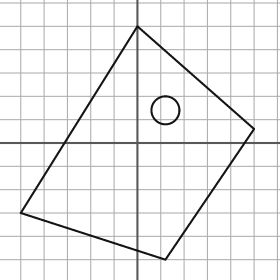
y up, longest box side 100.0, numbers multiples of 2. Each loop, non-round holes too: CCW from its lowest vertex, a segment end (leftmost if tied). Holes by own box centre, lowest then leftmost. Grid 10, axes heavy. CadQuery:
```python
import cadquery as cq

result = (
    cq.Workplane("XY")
    .moveTo(12.0, -50.0)
    .lineTo(50.0, 6.0)
    .lineTo(0.0, 50.0)
    .lineTo(-50.0, -30.0)
    .close()
    .moveTo(12.0, 14.0)
    .circle(6.0)
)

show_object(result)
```